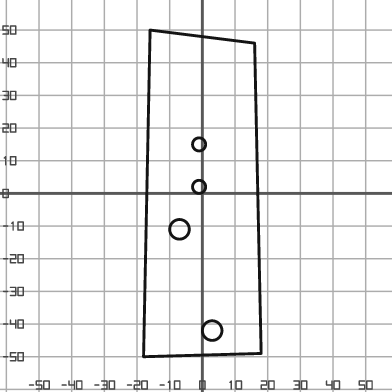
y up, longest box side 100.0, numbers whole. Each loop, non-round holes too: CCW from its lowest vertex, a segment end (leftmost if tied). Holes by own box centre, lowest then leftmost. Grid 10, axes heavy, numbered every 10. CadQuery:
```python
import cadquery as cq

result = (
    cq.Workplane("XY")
    .moveTo(-18.0, -50.0)
    .lineTo(18.0, -49.0)
    .lineTo(16.0, 46.0)
    .lineTo(-16.0, 50.0)
    .close()
    .moveTo(3.0, -42.0)
    .circle(3.0)
    .moveTo(-7.0, -11.0)
    .circle(3.0)
    .moveTo(-1.0, 2.0)
    .circle(2.0)
    .moveTo(-1.0, 15.0)
    .circle(2.0)
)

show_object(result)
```